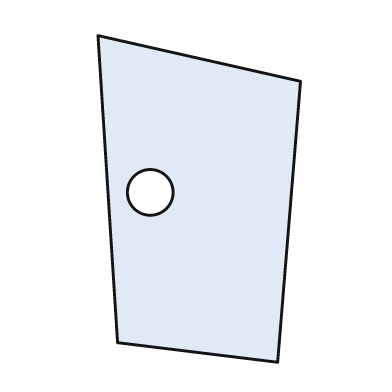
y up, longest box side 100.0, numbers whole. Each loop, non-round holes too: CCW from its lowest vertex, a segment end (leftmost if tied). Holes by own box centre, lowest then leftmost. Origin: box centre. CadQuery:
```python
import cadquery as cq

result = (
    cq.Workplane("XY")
    .moveTo(24.0, -50.0)
    .lineTo(31.0, 36.0)
    .lineTo(-31.0, 50.0)
    .lineTo(-25.0, -44.0)
    .close()
    .moveTo(-15.0, 2.0)
    .circle(7.0)
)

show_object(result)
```